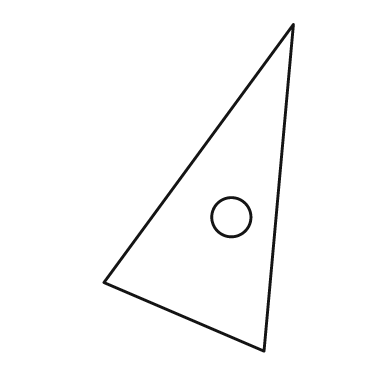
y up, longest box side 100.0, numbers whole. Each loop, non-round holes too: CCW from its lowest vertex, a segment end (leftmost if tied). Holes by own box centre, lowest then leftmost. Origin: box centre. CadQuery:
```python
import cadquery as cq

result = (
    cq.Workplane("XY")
    .moveTo(20.0, -50.0)
    .lineTo(29.0, 50.0)
    .lineTo(-29.0, -29.0)
    .close()
    .moveTo(10.0, -9.0)
    .circle(6.0)
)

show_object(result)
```